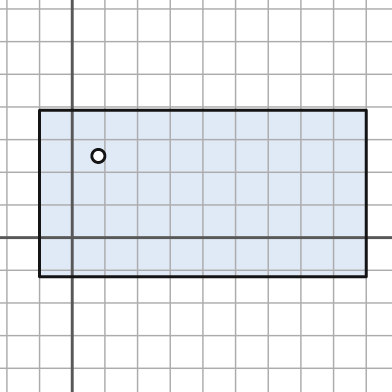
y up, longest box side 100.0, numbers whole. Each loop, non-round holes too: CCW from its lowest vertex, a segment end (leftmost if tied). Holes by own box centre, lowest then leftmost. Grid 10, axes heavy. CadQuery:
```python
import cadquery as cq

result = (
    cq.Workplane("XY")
    .moveTo(-10.0, -12.0)
    .lineTo(90.0, -12.0)
    .lineTo(90.0, 39.0)
    .lineTo(-10.0, 39.0)
    .close()
    .moveTo(8.0, 25.0)
    .circle(2.0)
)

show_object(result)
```